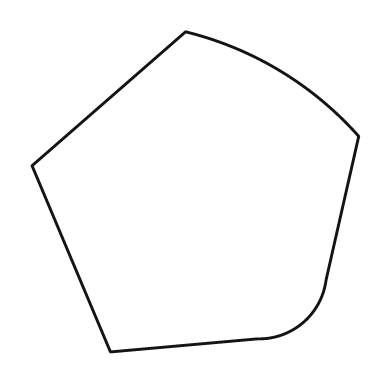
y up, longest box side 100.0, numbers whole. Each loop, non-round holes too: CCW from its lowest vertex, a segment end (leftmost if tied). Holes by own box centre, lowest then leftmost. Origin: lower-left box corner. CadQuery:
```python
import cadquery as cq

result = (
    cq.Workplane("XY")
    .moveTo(24.0, 0.0)
    .lineTo(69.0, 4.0)
    .threePointArc((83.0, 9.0), (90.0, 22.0))
    .lineTo(100.0, 66.0)
    .threePointArc((76.0, 86.0), (47.0, 98.0))
    .lineTo(0.0, 57.0)
    .close()
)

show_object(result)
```